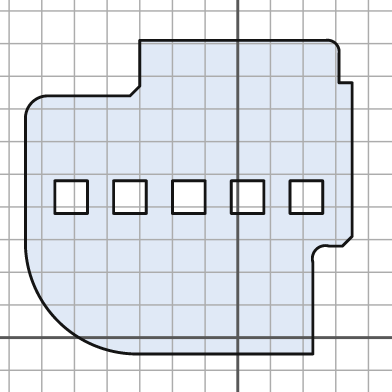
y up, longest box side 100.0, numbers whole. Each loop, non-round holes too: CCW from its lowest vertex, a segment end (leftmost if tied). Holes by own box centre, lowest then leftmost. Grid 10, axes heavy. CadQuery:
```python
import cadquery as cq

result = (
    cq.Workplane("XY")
    .moveTo(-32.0, -5.0)
    .lineTo(23.0, -5.0)
    .lineTo(23.0, 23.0)
    .threePointArc((24.0, 27.0), (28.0, 28.0))
    .lineTo(32.0, 28.0)
    .lineTo(35.0, 31.0)
    .lineTo(35.0, 78.0)
    .lineTo(31.0, 78.0)
    .lineTo(31.0, 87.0)
    .threePointArc((30.0, 90.0), (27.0, 91.0))
    .lineTo(-30.0, 91.0)
    .lineTo(-30.0, 77.0)
    .lineTo(-33.0, 74.0)
    .lineTo(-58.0, 74.0)
    .threePointArc((-63.0, 72.0), (-65.0, 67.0))
    .lineTo(-65.0, 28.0)
    .threePointArc((-55.0, 5.0), (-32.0, -5.0))
    .close()
    .moveTo(-56.0, 38.0)
    .lineTo(-46.0, 38.0)
    .lineTo(-46.0, 48.0)
    .lineTo(-56.0, 48.0)
    .close()
    .moveTo(-38.0, 38.0)
    .lineTo(-28.0, 38.0)
    .lineTo(-28.0, 48.0)
    .lineTo(-38.0, 48.0)
    .close()
    .moveTo(-20.0, 38.0)
    .lineTo(-10.0, 38.0)
    .lineTo(-10.0, 48.0)
    .lineTo(-20.0, 48.0)
    .close()
    .moveTo(-2.0, 38.0)
    .lineTo(8.0, 38.0)
    .lineTo(8.0, 48.0)
    .lineTo(-2.0, 48.0)
    .close()
    .moveTo(16.0, 38.0)
    .lineTo(26.0, 38.0)
    .lineTo(26.0, 48.0)
    .lineTo(16.0, 48.0)
    .close()
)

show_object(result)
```